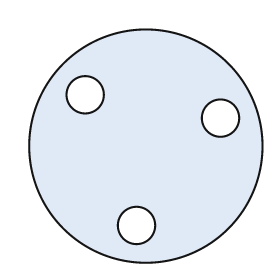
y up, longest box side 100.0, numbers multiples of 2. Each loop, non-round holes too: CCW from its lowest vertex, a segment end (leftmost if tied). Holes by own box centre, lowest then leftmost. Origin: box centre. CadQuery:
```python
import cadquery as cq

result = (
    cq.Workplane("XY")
    .moveTo(0.0, 0.0)
    .circle(50.0)
    .moveTo(-4.0, -34.0)
    .circle(8.0)
    .moveTo(32.0, 12.0)
    .circle(8.0)
    .moveTo(-26.0, 22.0)
    .circle(8.0)
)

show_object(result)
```